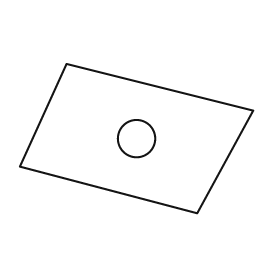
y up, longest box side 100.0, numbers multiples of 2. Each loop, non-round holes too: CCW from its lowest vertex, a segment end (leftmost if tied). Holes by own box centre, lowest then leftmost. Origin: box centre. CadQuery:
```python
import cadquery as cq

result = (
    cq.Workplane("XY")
    .moveTo(26.0, -32.0)
    .lineTo(50.0, 12.0)
    .lineTo(-30.0, 32.0)
    .lineTo(-50.0, -12.0)
    .close()
    .moveTo(0.0, 0.0)
    .circle(8.0)
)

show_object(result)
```